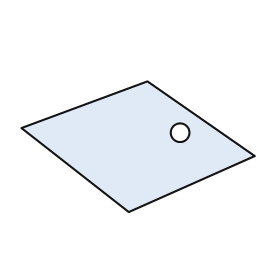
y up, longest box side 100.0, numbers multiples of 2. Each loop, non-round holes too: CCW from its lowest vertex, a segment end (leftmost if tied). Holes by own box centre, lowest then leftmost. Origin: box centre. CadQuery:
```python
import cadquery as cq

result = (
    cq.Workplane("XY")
    .moveTo(-4.0, -28.0)
    .lineTo(50.0, -4.0)
    .lineTo(4.0, 28.0)
    .lineTo(-50.0, 8.0)
    .close()
    .moveTo(18.0, 6.0)
    .circle(4.0)
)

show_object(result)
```